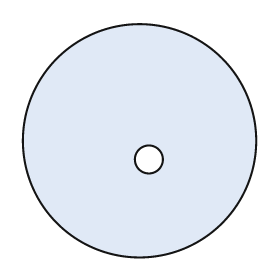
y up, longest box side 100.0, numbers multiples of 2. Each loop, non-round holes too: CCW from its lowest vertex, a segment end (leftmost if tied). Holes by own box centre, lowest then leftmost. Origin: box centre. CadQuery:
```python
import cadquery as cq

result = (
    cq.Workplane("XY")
    .moveTo(0.0, 0.0)
    .circle(50.0)
    .moveTo(4.0, -8.0)
    .circle(6.0)
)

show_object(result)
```